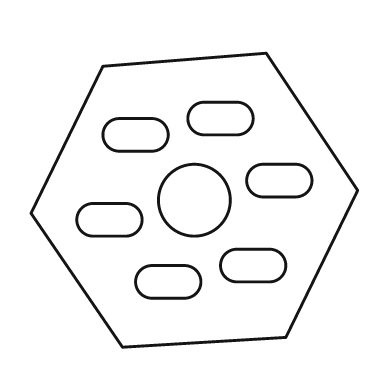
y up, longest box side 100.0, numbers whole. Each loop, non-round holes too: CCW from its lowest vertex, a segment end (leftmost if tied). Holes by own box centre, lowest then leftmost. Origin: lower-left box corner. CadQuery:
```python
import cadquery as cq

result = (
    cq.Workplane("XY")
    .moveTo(28.0, 0.0)
    .lineTo(78.0, 3.0)
    .lineTo(100.0, 48.0)
    .lineTo(72.0, 90.0)
    .lineTo(22.0, 86.0)
    .lineTo(0.0, 41.0)
    .close()
    .moveTo(37.0, 15.0)
    .lineTo(47.0, 15.0)
    .threePointArc((52.0, 20.0), (47.0, 25.0))
    .lineTo(37.0, 25.0)
    .threePointArc((32.0, 20.0), (37.0, 15.0))
    .close()
    .moveTo(63.0, 20.0)
    .lineTo(73.0, 20.0)
    .threePointArc((78.0, 25.0), (73.0, 30.0))
    .lineTo(63.0, 30.0)
    .threePointArc((58.0, 25.0), (63.0, 20.0))
    .close()
    .moveTo(19.0, 34.0)
    .lineTo(29.0, 34.0)
    .threePointArc((34.0, 39.0), (29.0, 44.0))
    .lineTo(19.0, 44.0)
    .threePointArc((14.0, 39.0), (19.0, 34.0))
    .close()
    .moveTo(50.0, 45.0)
    .circle(11.0)
    .moveTo(71.0, 46.0)
    .lineTo(81.0, 46.0)
    .threePointArc((86.0, 51.0), (81.0, 56.0))
    .lineTo(71.0, 56.0)
    .threePointArc((66.0, 51.0), (71.0, 46.0))
    .close()
    .moveTo(27.0, 60.0)
    .lineTo(37.0, 60.0)
    .threePointArc((42.0, 65.0), (37.0, 70.0))
    .lineTo(27.0, 70.0)
    .threePointArc((22.0, 65.0), (27.0, 60.0))
    .close()
    .moveTo(53.0, 65.0)
    .lineTo(63.0, 65.0)
    .threePointArc((68.0, 70.0), (63.0, 75.0))
    .lineTo(53.0, 75.0)
    .threePointArc((48.0, 70.0), (53.0, 65.0))
    .close()
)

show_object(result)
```